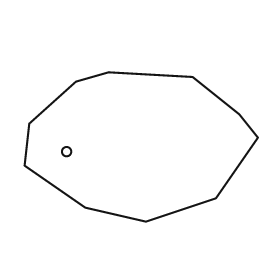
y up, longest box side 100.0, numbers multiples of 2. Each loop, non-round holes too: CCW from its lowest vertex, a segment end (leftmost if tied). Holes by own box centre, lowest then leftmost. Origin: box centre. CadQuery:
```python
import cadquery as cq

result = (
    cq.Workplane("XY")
    .moveTo(2.0, -32.0)
    .lineTo(32.0, -22.0)
    .lineTo(50.0, 4.0)
    .lineTo(42.0, 14.0)
    .lineTo(22.0, 30.0)
    .lineTo(-14.0, 32.0)
    .lineTo(-28.0, 28.0)
    .lineTo(-48.0, 10.0)
    .lineTo(-50.0, -8.0)
    .lineTo(-24.0, -26.0)
    .close()
    .moveTo(-32.0, -2.0)
    .circle(2.0)
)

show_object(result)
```